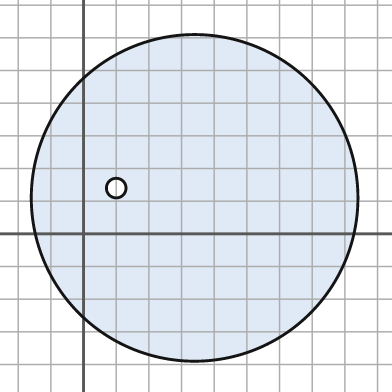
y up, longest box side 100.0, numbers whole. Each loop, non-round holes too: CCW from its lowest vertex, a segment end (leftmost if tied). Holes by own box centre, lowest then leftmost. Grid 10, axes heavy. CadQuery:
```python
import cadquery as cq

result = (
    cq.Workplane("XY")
    .moveTo(34.0, 11.0)
    .circle(50.0)
    .moveTo(10.0, 14.0)
    .circle(3.0)
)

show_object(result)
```